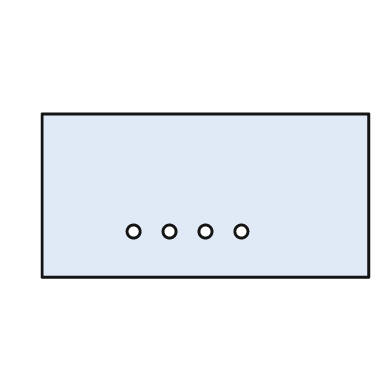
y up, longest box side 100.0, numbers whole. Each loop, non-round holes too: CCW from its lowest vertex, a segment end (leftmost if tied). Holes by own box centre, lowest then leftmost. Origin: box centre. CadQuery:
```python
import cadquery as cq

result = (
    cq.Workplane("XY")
    .moveTo(-50.0, -25.0)
    .lineTo(50.0, -25.0)
    .lineTo(50.0, 25.0)
    .lineTo(-50.0, 25.0)
    .close()
    .moveTo(-22.0, -11.0)
    .circle(2.0)
    .moveTo(-11.0, -11.0)
    .circle(2.0)
    .moveTo(0.0, -11.0)
    .circle(2.0)
    .moveTo(11.0, -11.0)
    .circle(2.0)
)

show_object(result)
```